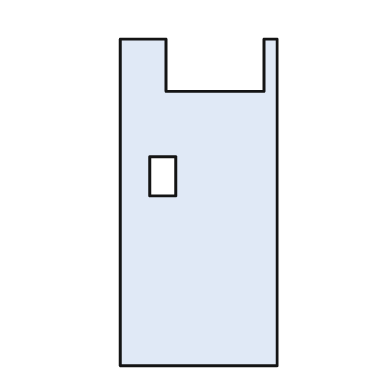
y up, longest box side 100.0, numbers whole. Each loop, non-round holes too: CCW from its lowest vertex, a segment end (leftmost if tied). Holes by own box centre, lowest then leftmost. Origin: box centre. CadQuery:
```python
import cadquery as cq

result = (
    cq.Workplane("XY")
    .moveTo(-24.0, -50.0)
    .lineTo(24.0, -50.0)
    .lineTo(24.0, 50.0)
    .lineTo(20.0, 50.0)
    .lineTo(20.0, 34.0)
    .lineTo(-10.0, 34.0)
    .lineTo(-10.0, 50.0)
    .lineTo(-24.0, 50.0)
    .close()
    .moveTo(-15.0, 2.0)
    .lineTo(-7.0, 2.0)
    .lineTo(-7.0, 14.0)
    .lineTo(-15.0, 14.0)
    .close()
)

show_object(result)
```